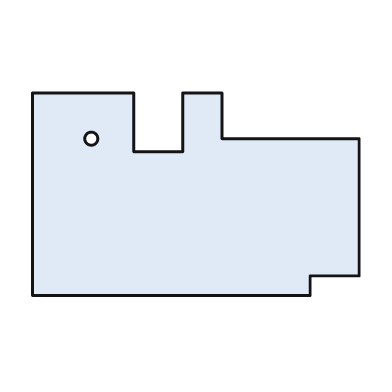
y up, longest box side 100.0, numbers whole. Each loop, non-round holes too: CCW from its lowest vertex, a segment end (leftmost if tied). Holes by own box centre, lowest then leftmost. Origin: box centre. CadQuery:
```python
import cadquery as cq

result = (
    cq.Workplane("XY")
    .moveTo(-50.0, -31.0)
    .lineTo(35.0, -31.0)
    .lineTo(35.0, -25.0)
    .lineTo(50.0, -25.0)
    .lineTo(50.0, 17.0)
    .lineTo(8.0, 17.0)
    .lineTo(8.0, 31.0)
    .lineTo(-4.0, 31.0)
    .lineTo(-4.0, 13.0)
    .lineTo(-19.0, 13.0)
    .lineTo(-19.0, 31.0)
    .lineTo(-50.0, 31.0)
    .close()
    .moveTo(-32.0, 17.0)
    .circle(2.0)
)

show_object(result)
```